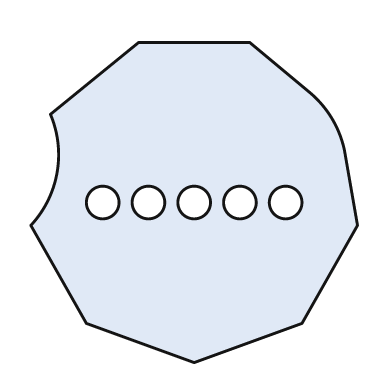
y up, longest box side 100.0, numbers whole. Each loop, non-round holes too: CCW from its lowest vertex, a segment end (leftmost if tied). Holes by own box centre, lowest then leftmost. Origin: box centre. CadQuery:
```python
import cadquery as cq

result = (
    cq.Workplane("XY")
    .moveTo(0.0, -49.0)
    .lineTo(33.0, -37.0)
    .lineTo(50.0, -7.0)
    .lineTo(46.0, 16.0)
    .threePointArc((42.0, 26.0), (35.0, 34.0))
    .lineTo(17.0, 49.0)
    .lineTo(-17.0, 49.0)
    .lineTo(-44.0, 27.0)
    .threePointArc((-42.0, 9.0), (-50.0, -7.0))
    .lineTo(-33.0, -37.0)
    .close()
    .moveTo(-28.0, 0.0)
    .circle(5.0)
    .moveTo(-14.0, 0.0)
    .circle(5.0)
    .moveTo(0.0, 0.0)
    .circle(5.0)
    .moveTo(14.0, 0.0)
    .circle(5.0)
    .moveTo(28.0, 0.0)
    .circle(5.0)
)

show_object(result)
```